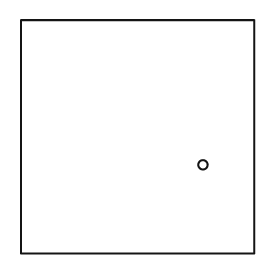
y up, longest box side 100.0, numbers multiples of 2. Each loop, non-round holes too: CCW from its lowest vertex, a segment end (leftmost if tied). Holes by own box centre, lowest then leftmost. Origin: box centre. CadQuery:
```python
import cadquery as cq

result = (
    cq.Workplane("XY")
    .moveTo(-50.0, -50.0)
    .lineTo(50.0, -50.0)
    .lineTo(50.0, 50.0)
    .lineTo(-50.0, 50.0)
    .close()
    .moveTo(28.0, -12.0)
    .circle(2.0)
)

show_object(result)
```